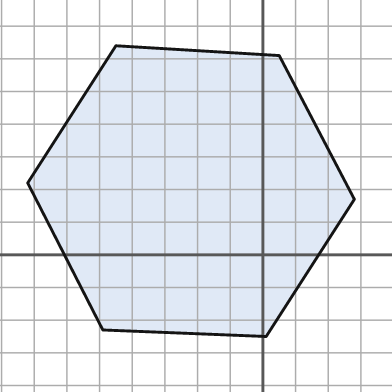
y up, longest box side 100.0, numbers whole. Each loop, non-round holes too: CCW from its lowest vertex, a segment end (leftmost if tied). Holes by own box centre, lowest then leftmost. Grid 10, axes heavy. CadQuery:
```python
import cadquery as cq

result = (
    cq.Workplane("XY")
    .moveTo(1.0, -25.0)
    .lineTo(28.0, 17.0)
    .lineTo(5.0, 61.0)
    .lineTo(-45.0, 64.0)
    .lineTo(-72.0, 22.0)
    .lineTo(-49.0, -23.0)
    .close()
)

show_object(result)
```